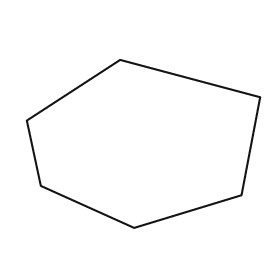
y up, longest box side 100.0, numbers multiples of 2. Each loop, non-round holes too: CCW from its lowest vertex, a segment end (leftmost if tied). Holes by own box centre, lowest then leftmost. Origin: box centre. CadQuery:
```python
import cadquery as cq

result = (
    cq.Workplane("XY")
    .moveTo(-4.0, -36.0)
    .lineTo(42.0, -22.0)
    .lineTo(50.0, 20.0)
    .lineTo(-10.0, 36.0)
    .lineTo(-50.0, 10.0)
    .lineTo(-44.0, -18.0)
    .close()
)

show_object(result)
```